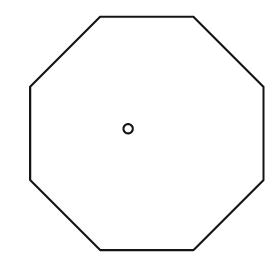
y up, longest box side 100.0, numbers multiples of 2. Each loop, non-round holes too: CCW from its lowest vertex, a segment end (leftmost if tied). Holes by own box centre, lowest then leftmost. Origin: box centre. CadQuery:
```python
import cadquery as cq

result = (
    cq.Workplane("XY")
    .moveTo(-20.0, -50.0)
    .lineTo(20.0, -50.0)
    .lineTo(50.0, -20.0)
    .lineTo(50.0, 20.0)
    .lineTo(20.0, 50.0)
    .lineTo(-20.0, 50.0)
    .lineTo(-50.0, 20.0)
    .lineTo(-50.0, -20.0)
    .close()
    .moveTo(-8.0, 2.0)
    .circle(2.0)
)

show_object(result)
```